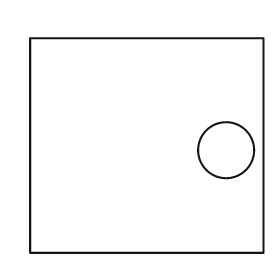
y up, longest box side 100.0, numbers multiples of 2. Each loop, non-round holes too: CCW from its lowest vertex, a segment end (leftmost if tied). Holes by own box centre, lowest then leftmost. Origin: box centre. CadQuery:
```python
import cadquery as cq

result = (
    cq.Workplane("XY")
    .moveTo(-50.0, -46.0)
    .lineTo(50.0, -46.0)
    .lineTo(50.0, 46.0)
    .lineTo(-50.0, 46.0)
    .close()
    .moveTo(34.0, -2.0)
    .circle(12.0)
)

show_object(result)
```